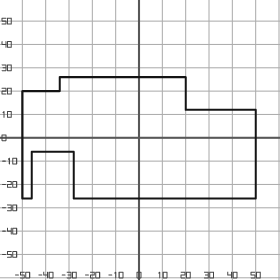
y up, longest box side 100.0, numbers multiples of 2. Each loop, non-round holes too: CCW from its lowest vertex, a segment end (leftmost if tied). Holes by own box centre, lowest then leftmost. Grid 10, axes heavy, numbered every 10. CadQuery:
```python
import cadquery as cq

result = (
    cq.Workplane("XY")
    .moveTo(-50.0, -26.0)
    .lineTo(-46.0, -26.0)
    .lineTo(-46.0, -6.0)
    .lineTo(-28.0, -6.0)
    .lineTo(-28.0, -26.0)
    .lineTo(50.0, -26.0)
    .lineTo(50.0, 12.0)
    .lineTo(20.0, 12.0)
    .lineTo(20.0, 26.0)
    .lineTo(-34.0, 26.0)
    .lineTo(-34.0, 20.0)
    .lineTo(-50.0, 20.0)
    .close()
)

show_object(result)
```